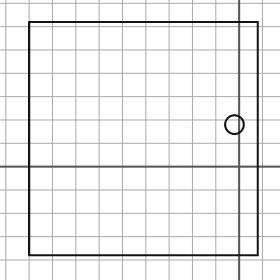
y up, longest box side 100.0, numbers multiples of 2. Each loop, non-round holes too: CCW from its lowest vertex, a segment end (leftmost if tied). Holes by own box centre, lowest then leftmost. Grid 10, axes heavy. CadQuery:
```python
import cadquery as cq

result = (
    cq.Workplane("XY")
    .moveTo(-90.0, -38.0)
    .lineTo(8.0, -38.0)
    .lineTo(8.0, 62.0)
    .lineTo(-90.0, 62.0)
    .close()
    .moveTo(-2.0, 18.0)
    .circle(4.0)
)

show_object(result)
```